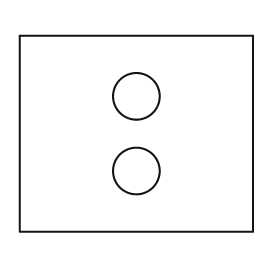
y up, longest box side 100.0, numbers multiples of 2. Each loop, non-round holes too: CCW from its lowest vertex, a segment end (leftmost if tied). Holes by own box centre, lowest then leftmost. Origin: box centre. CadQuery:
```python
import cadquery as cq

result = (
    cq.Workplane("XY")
    .moveTo(-50.0, -42.0)
    .lineTo(50.0, -42.0)
    .lineTo(50.0, 42.0)
    .lineTo(-50.0, 42.0)
    .close()
    .moveTo(0.0, -16.0)
    .circle(10.0)
    .moveTo(0.0, 16.0)
    .circle(10.0)
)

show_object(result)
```